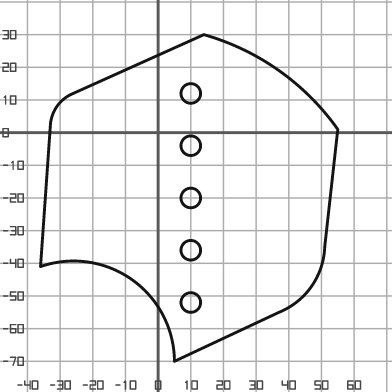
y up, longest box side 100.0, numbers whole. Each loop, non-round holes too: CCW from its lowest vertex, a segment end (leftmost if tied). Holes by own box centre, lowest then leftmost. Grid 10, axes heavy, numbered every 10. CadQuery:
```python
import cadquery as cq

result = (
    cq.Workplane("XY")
    .moveTo(5.0, -70.0)
    .lineTo(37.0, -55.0)
    .threePointArc((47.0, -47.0), (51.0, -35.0))
    .lineTo(55.0, 1.0)
    .threePointArc((37.0, 19.0), (14.0, 30.0))
    .lineTo(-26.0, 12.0)
    .threePointArc((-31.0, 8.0), (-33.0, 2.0))
    .lineTo(-36.0, -41.0)
    .threePointArc((-8.0, -45.0), (5.0, -70.0))
    .close()
    .moveTo(10.0, -52.0)
    .circle(3.0)
    .moveTo(10.0, -36.0)
    .circle(3.0)
    .moveTo(10.0, -20.0)
    .circle(3.0)
    .moveTo(10.0, -4.0)
    .circle(3.0)
    .moveTo(10.0, 12.0)
    .circle(3.0)
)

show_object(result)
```